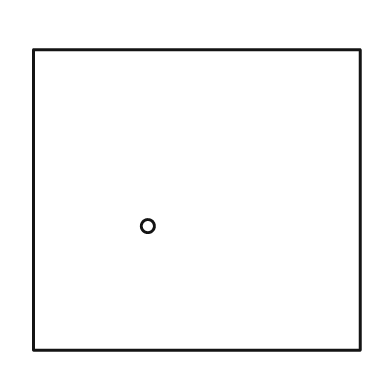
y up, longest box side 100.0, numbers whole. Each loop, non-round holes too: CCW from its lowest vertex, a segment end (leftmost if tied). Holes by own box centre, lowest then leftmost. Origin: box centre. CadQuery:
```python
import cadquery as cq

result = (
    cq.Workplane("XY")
    .moveTo(-50.0, -46.0)
    .lineTo(50.0, -46.0)
    .lineTo(50.0, 46.0)
    .lineTo(-50.0, 46.0)
    .close()
    .moveTo(-15.0, -8.0)
    .circle(2.0)
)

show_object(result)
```